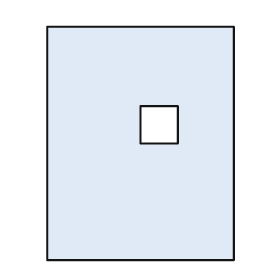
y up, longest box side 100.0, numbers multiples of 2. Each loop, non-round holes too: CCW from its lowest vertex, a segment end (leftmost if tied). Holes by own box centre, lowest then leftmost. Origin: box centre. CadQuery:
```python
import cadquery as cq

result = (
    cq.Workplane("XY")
    .moveTo(-40.0, -50.0)
    .lineTo(40.0, -50.0)
    .lineTo(40.0, 50.0)
    .lineTo(-40.0, 50.0)
    .close()
    .moveTo(0.0, 0.0)
    .lineTo(16.0, 0.0)
    .lineTo(16.0, 16.0)
    .lineTo(0.0, 16.0)
    .close()
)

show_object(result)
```